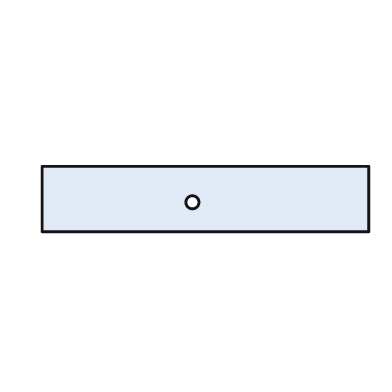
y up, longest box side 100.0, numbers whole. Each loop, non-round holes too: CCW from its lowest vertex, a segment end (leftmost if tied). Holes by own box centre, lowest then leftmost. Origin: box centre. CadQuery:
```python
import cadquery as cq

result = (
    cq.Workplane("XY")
    .moveTo(-50.0, -10.0)
    .lineTo(50.0, -10.0)
    .lineTo(50.0, 10.0)
    .lineTo(-50.0, 10.0)
    .close()
    .moveTo(-4.0, -1.0)
    .circle(2.0)
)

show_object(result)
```